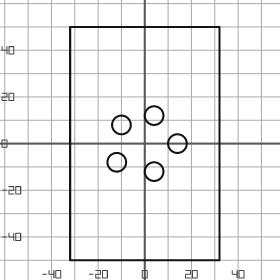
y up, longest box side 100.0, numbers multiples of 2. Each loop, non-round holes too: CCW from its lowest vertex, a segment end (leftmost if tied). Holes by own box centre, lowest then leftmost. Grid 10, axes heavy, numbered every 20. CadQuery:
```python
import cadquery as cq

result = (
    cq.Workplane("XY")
    .moveTo(-32.0, -50.0)
    .lineTo(32.0, -50.0)
    .lineTo(32.0, 50.0)
    .lineTo(-32.0, 50.0)
    .close()
    .moveTo(4.0, -12.0)
    .circle(4.0)
    .moveTo(-12.0, -8.0)
    .circle(4.0)
    .moveTo(14.0, 0.0)
    .circle(4.0)
    .moveTo(-10.0, 8.0)
    .circle(4.0)
    .moveTo(4.0, 12.0)
    .circle(4.0)
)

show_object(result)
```